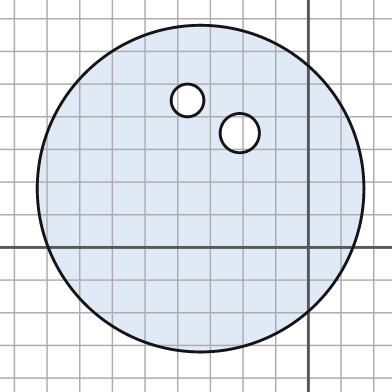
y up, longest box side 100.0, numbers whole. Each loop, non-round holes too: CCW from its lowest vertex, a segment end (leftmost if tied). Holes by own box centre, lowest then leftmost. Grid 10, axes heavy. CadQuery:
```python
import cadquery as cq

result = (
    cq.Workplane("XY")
    .moveTo(-33.0, 18.0)
    .circle(50.0)
    .moveTo(-21.0, 35.0)
    .circle(6.0)
    .moveTo(-37.0, 45.0)
    .circle(5.0)
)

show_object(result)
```